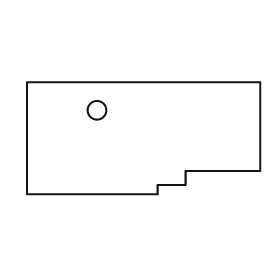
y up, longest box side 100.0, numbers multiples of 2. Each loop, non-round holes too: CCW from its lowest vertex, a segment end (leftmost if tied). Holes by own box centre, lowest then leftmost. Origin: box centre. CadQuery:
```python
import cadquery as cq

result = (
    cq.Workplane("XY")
    .moveTo(-50.0, -24.0)
    .lineTo(6.0, -24.0)
    .lineTo(6.0, -20.0)
    .lineTo(18.0, -20.0)
    .lineTo(18.0, -14.0)
    .lineTo(50.0, -14.0)
    .lineTo(50.0, 24.0)
    .lineTo(-50.0, 24.0)
    .close()
    .moveTo(-20.0, 12.0)
    .circle(4.0)
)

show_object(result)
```